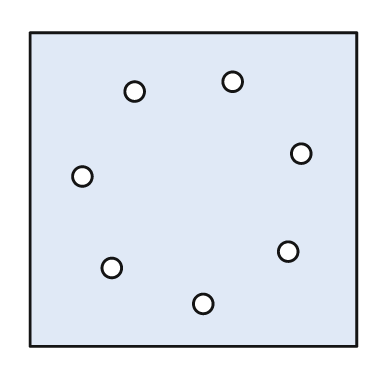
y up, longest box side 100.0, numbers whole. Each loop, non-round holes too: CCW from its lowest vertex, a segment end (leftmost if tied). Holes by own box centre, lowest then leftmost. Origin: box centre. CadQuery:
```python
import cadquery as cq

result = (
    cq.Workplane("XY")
    .moveTo(-50.0, -48.0)
    .lineTo(50.0, -48.0)
    .lineTo(50.0, 48.0)
    .lineTo(-50.0, 48.0)
    .close()
    .moveTo(3.0, -35.0)
    .circle(3.0)
    .moveTo(-25.0, -24.0)
    .circle(3.0)
    .moveTo(29.0, -19.0)
    .circle(3.0)
    .moveTo(-34.0, 4.0)
    .circle(3.0)
    .moveTo(33.0, 11.0)
    .circle(3.0)
    .moveTo(-18.0, 30.0)
    .circle(3.0)
    .moveTo(12.0, 33.0)
    .circle(3.0)
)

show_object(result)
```